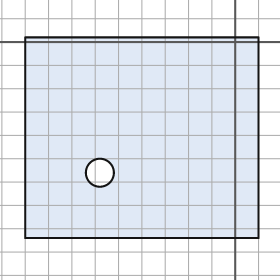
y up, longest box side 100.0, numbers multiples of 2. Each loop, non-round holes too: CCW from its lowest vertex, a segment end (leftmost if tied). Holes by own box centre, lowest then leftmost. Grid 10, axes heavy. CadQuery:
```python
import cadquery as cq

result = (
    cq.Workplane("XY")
    .moveTo(-90.0, -84.0)
    .lineTo(10.0, -84.0)
    .lineTo(10.0, 2.0)
    .lineTo(-90.0, 2.0)
    .close()
    .moveTo(-58.0, -56.0)
    .circle(6.0)
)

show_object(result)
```